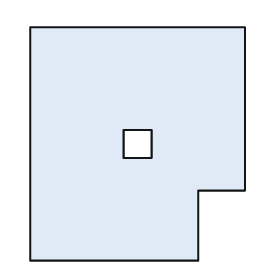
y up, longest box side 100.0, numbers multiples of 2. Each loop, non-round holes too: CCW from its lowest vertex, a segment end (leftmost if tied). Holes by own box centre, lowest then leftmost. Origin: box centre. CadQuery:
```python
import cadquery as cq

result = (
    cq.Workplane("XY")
    .moveTo(-46.0, -50.0)
    .lineTo(26.0, -50.0)
    .lineTo(26.0, -20.0)
    .lineTo(46.0, -20.0)
    .lineTo(46.0, 50.0)
    .lineTo(-46.0, 50.0)
    .close()
    .moveTo(-6.0, -6.0)
    .lineTo(6.0, -6.0)
    .lineTo(6.0, 6.0)
    .lineTo(-6.0, 6.0)
    .close()
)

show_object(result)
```